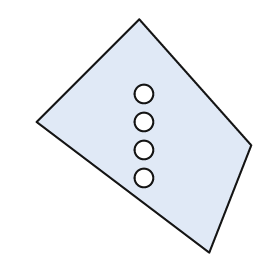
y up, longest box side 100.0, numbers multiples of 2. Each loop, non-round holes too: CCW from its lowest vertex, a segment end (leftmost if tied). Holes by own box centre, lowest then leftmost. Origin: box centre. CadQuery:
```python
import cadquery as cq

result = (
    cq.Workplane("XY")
    .moveTo(28.0, -50.0)
    .lineTo(46.0, -4.0)
    .lineTo(-2.0, 50.0)
    .lineTo(-46.0, 6.0)
    .close()
    .moveTo(0.0, -18.0)
    .circle(4.0)
    .moveTo(0.0, -6.0)
    .circle(4.0)
    .moveTo(0.0, 6.0)
    .circle(4.0)
    .moveTo(0.0, 18.0)
    .circle(4.0)
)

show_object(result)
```